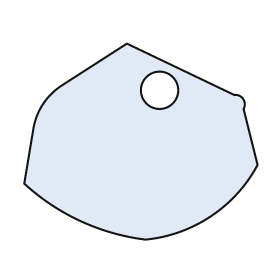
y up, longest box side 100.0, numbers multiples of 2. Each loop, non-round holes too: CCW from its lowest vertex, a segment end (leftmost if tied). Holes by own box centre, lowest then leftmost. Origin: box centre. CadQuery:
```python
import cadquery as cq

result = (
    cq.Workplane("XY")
    .moveTo(2.0, -42.0)
    .threePointArc((30.0, -32.0), (50.0, -10.0))
    .lineTo(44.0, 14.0)
    .threePointArc((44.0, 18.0), (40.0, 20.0))
    .lineTo(-6.0, 42.0)
    .lineTo(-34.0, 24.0)
    .threePointArc((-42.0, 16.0), (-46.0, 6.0))
    .lineTo(-50.0, -18.0)
    .threePointArc((-26.0, -34.0), (2.0, -42.0))
    .close()
    .moveTo(8.0, 22.0)
    .circle(8.0)
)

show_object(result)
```